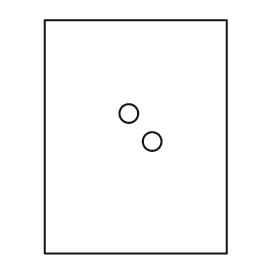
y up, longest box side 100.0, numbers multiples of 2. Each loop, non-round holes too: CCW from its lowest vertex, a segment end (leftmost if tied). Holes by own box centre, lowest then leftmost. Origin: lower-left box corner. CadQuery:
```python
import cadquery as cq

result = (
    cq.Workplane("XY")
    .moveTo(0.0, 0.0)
    .lineTo(78.0, 0.0)
    .lineTo(78.0, 100.0)
    .lineTo(0.0, 100.0)
    .close()
    .moveTo(46.0, 48.0)
    .circle(4.0)
    .moveTo(36.0, 60.0)
    .circle(4.0)
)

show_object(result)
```